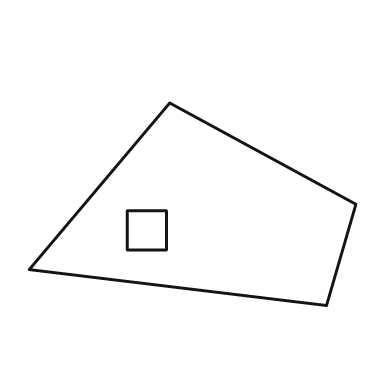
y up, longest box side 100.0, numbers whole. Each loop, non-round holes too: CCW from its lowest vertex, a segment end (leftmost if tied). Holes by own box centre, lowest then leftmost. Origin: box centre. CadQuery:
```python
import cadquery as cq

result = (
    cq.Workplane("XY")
    .moveTo(41.0, -31.0)
    .lineTo(50.0, 0.0)
    .lineTo(-7.0, 31.0)
    .lineTo(-50.0, -20.0)
    .close()
    .moveTo(-20.0, -14.0)
    .lineTo(-8.0, -14.0)
    .lineTo(-8.0, -2.0)
    .lineTo(-20.0, -2.0)
    .close()
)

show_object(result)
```